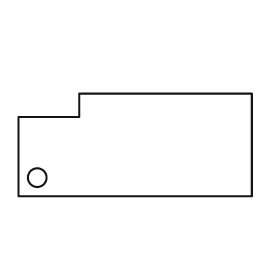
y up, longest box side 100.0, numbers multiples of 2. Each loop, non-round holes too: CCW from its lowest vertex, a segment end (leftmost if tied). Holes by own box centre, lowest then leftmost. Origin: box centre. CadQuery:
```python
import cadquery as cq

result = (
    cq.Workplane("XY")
    .moveTo(-50.0, -22.0)
    .lineTo(50.0, -22.0)
    .lineTo(50.0, 22.0)
    .lineTo(-24.0, 22.0)
    .lineTo(-24.0, 12.0)
    .lineTo(-50.0, 12.0)
    .close()
    .moveTo(-42.0, -14.0)
    .circle(4.0)
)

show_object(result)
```